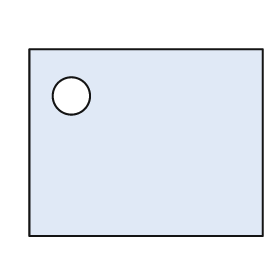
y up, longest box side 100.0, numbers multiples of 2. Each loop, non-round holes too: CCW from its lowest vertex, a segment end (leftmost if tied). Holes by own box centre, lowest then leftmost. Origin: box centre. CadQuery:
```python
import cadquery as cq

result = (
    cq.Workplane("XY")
    .moveTo(-50.0, -40.0)
    .lineTo(50.0, -40.0)
    .lineTo(50.0, 40.0)
    .lineTo(-50.0, 40.0)
    .close()
    .moveTo(-32.0, 20.0)
    .circle(8.0)
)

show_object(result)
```